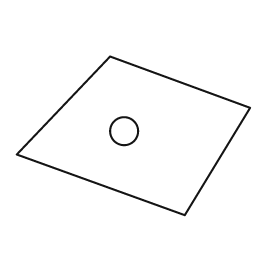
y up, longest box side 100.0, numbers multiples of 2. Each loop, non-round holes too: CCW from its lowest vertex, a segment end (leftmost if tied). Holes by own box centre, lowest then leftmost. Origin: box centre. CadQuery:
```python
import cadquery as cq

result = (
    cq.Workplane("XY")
    .moveTo(22.0, -34.0)
    .lineTo(50.0, 12.0)
    .lineTo(-10.0, 34.0)
    .lineTo(-50.0, -8.0)
    .close()
    .moveTo(-4.0, 2.0)
    .circle(6.0)
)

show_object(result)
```